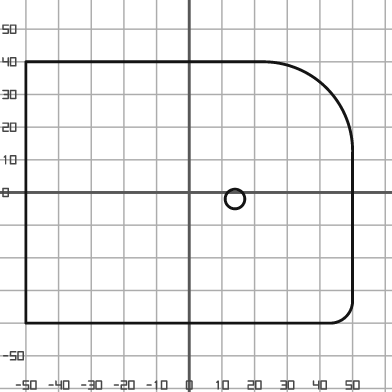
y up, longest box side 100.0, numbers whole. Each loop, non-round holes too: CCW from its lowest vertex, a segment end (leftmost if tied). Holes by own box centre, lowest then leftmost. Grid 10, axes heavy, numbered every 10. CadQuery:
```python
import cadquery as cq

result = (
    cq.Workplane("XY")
    .moveTo(-50.0, -40.0)
    .lineTo(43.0, -40.0)
    .threePointArc((48.0, -38.0), (50.0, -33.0))
    .lineTo(50.0, 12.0)
    .threePointArc((42.0, 32.0), (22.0, 40.0))
    .lineTo(-50.0, 40.0)
    .close()
    .moveTo(14.0, -2.0)
    .circle(3.0)
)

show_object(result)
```